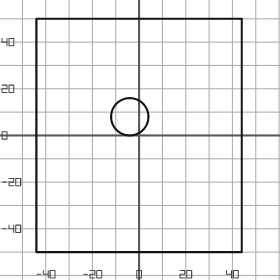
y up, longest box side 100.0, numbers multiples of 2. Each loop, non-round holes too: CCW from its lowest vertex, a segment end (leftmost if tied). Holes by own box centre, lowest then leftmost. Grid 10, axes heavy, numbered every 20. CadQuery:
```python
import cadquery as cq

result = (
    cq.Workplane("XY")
    .moveTo(-44.0, -50.0)
    .lineTo(44.0, -50.0)
    .lineTo(44.0, 50.0)
    .lineTo(-44.0, 50.0)
    .close()
    .moveTo(-4.0, 8.0)
    .circle(8.0)
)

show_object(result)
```